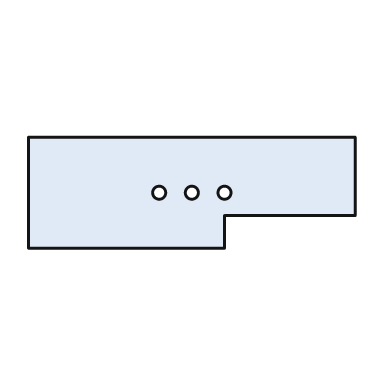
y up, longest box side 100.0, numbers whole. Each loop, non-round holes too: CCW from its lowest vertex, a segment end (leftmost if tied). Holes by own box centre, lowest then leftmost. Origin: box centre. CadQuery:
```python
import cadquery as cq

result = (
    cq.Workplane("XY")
    .moveTo(-50.0, -17.0)
    .lineTo(10.0, -17.0)
    .lineTo(10.0, -7.0)
    .lineTo(50.0, -7.0)
    .lineTo(50.0, 17.0)
    .lineTo(-50.0, 17.0)
    .close()
    .moveTo(-10.0, 0.0)
    .circle(2.0)
    .moveTo(0.0, 0.0)
    .circle(2.0)
    .moveTo(10.0, 0.0)
    .circle(2.0)
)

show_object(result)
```